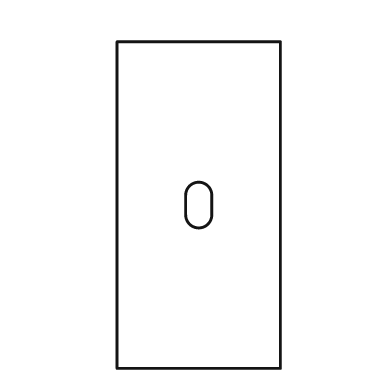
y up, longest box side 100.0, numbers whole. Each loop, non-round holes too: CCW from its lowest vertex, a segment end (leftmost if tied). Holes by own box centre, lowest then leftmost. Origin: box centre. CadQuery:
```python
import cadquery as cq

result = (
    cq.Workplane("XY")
    .moveTo(-25.0, -50.0)
    .lineTo(25.0, -50.0)
    .lineTo(25.0, 50.0)
    .lineTo(-25.0, 50.0)
    .close()
    .moveTo(-4.0, -3.0)
    .threePointArc((0.0, -7.0), (4.0, -3.0))
    .lineTo(4.0, 3.0)
    .threePointArc((0.0, 7.0), (-4.0, 3.0))
    .close()
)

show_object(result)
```